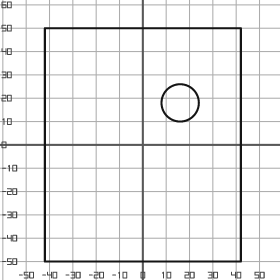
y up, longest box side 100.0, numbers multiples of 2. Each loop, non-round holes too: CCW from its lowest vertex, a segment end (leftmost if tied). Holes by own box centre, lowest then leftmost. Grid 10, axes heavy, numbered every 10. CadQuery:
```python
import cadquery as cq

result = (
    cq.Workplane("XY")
    .moveTo(-42.0, -50.0)
    .lineTo(42.0, -50.0)
    .lineTo(42.0, 50.0)
    .lineTo(-42.0, 50.0)
    .close()
    .moveTo(16.0, 18.0)
    .circle(8.0)
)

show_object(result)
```